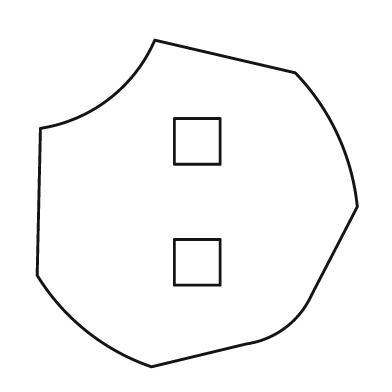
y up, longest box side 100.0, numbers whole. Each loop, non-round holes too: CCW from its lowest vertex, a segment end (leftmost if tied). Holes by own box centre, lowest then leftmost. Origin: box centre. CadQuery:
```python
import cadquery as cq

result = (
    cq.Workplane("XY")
    .moveTo(-14.0, -50.0)
    .lineTo(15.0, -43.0)
    .threePointArc((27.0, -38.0), (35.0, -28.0))
    .lineTo(49.0, -1.0)
    .threePointArc((43.0, 21.0), (30.0, 40.0))
    .lineTo(-13.0, 50.0)
    .threePointArc((-27.0, 32.0), (-48.0, 23.0))
    .lineTo(-49.0, -22.0)
    .threePointArc((-34.0, -39.0), (-14.0, -50.0))
    .close()
    .moveTo(-7.0, -25.0)
    .lineTo(7.0, -25.0)
    .lineTo(7.0, -11.0)
    .lineTo(-7.0, -11.0)
    .close()
    .moveTo(-7.0, 12.0)
    .lineTo(7.0, 12.0)
    .lineTo(7.0, 26.0)
    .lineTo(-7.0, 26.0)
    .close()
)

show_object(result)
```